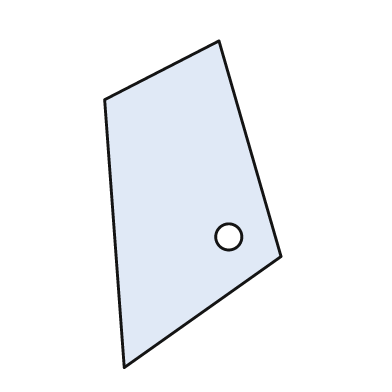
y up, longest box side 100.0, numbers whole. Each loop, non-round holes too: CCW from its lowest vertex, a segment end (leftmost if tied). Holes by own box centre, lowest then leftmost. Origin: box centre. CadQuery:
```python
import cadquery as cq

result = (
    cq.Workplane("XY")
    .moveTo(-21.0, -50.0)
    .lineTo(27.0, -16.0)
    .lineTo(8.0, 50.0)
    .lineTo(-27.0, 32.0)
    .close()
    .moveTo(11.0, -10.0)
    .circle(4.0)
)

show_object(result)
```